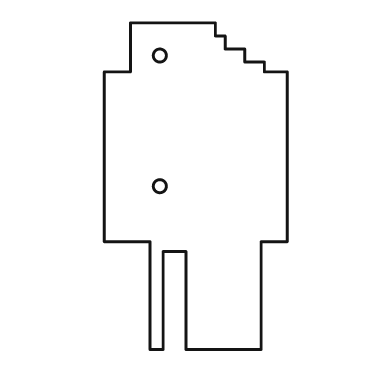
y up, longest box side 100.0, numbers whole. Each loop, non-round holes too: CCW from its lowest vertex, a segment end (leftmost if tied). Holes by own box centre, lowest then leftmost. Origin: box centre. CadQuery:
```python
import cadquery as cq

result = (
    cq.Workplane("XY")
    .moveTo(-14.0, -50.0)
    .lineTo(-10.0, -50.0)
    .lineTo(-10.0, -20.0)
    .lineTo(-3.0, -20.0)
    .lineTo(-3.0, -50.0)
    .lineTo(20.0, -50.0)
    .lineTo(20.0, -17.0)
    .lineTo(28.0, -17.0)
    .lineTo(28.0, 35.0)
    .lineTo(21.0, 35.0)
    .lineTo(21.0, 38.0)
    .lineTo(15.0, 38.0)
    .lineTo(15.0, 42.0)
    .lineTo(9.0, 42.0)
    .lineTo(9.0, 46.0)
    .lineTo(6.0, 46.0)
    .lineTo(6.0, 50.0)
    .lineTo(-20.0, 50.0)
    .lineTo(-20.0, 35.0)
    .lineTo(-28.0, 35.0)
    .lineTo(-28.0, -17.0)
    .lineTo(-14.0, -17.0)
    .close()
    .moveTo(-11.0, 0.0)
    .circle(2.0)
    .moveTo(-11.0, 40.0)
    .circle(2.0)
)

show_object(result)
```